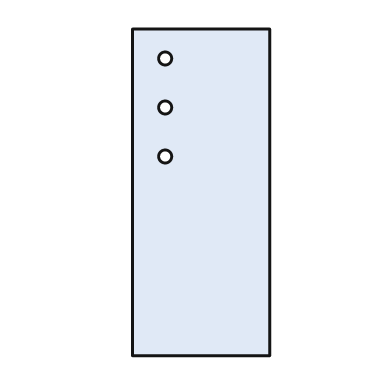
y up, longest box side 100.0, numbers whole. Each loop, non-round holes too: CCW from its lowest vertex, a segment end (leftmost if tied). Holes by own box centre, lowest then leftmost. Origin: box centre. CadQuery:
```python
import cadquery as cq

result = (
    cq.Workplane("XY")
    .moveTo(-21.0, -50.0)
    .lineTo(21.0, -50.0)
    .lineTo(21.0, 50.0)
    .lineTo(-21.0, 50.0)
    .close()
    .moveTo(-11.0, 11.0)
    .circle(2.0)
    .moveTo(-11.0, 26.0)
    .circle(2.0)
    .moveTo(-11.0, 41.0)
    .circle(2.0)
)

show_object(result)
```